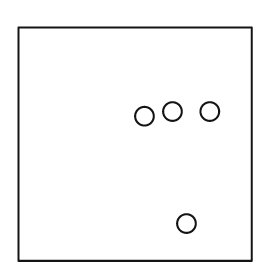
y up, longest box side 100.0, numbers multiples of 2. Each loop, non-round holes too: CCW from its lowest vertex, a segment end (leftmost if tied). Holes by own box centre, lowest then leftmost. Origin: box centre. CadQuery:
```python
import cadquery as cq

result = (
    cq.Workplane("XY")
    .moveTo(-50.0, -50.0)
    .lineTo(50.0, -50.0)
    .lineTo(50.0, 50.0)
    .lineTo(-50.0, 50.0)
    .close()
    .moveTo(22.0, -34.0)
    .circle(4.0)
    .moveTo(4.0, 12.0)
    .circle(4.0)
    .moveTo(16.0, 14.0)
    .circle(4.0)
    .moveTo(32.0, 14.0)
    .circle(4.0)
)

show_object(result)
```